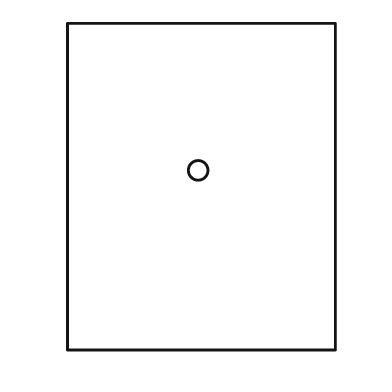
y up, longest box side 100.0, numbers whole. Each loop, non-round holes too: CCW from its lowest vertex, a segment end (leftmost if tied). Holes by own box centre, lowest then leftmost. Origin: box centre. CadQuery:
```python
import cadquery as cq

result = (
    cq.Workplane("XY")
    .moveTo(-41.0, -50.0)
    .lineTo(41.0, -50.0)
    .lineTo(41.0, 50.0)
    .lineTo(-41.0, 50.0)
    .close()
    .moveTo(-1.0, 5.0)
    .circle(3.0)
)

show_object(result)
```